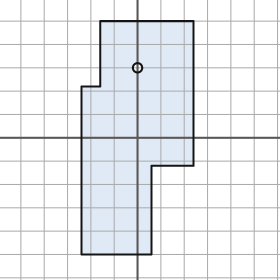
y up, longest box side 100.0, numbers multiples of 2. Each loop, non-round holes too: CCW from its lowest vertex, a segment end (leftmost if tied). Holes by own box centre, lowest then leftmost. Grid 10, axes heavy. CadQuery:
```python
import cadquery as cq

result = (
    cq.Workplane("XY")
    .moveTo(-24.0, -50.0)
    .lineTo(6.0, -50.0)
    .lineTo(6.0, -12.0)
    .lineTo(24.0, -12.0)
    .lineTo(24.0, 50.0)
    .lineTo(-16.0, 50.0)
    .lineTo(-16.0, 22.0)
    .lineTo(-24.0, 22.0)
    .close()
    .moveTo(0.0, 30.0)
    .circle(2.0)
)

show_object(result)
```